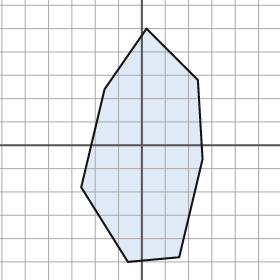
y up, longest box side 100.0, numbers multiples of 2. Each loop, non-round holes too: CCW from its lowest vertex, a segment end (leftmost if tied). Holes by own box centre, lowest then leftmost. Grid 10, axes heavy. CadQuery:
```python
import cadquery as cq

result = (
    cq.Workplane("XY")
    .moveTo(-6.0, -50.0)
    .lineTo(16.0, -48.0)
    .lineTo(26.0, -6.0)
    .lineTo(24.0, 28.0)
    .lineTo(2.0, 50.0)
    .lineTo(-16.0, 24.0)
    .lineTo(-26.0, -18.0)
    .close()
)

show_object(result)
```